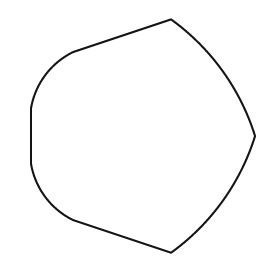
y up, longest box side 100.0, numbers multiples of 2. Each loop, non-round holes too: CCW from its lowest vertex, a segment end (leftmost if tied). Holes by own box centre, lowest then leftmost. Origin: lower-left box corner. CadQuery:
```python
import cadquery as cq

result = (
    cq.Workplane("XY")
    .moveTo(60.0, 0.0)
    .threePointArc((82.0, 22.0), (96.0, 50.0))
    .threePointArc((82.0, 78.0), (60.0, 100.0))
    .lineTo(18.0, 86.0)
    .threePointArc((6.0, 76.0), (0.0, 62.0))
    .lineTo(0.0, 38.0)
    .threePointArc((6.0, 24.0), (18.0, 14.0))
    .close()
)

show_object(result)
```